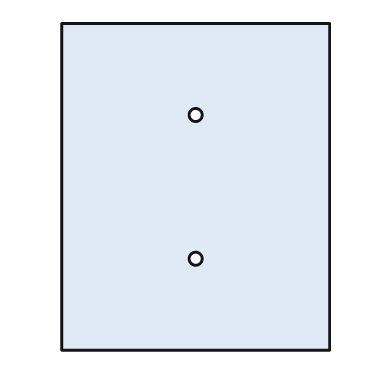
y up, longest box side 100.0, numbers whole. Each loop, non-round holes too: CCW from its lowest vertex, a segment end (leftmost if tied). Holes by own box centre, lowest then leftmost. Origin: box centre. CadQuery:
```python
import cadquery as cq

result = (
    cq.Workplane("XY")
    .moveTo(-41.0, -50.0)
    .lineTo(41.0, -50.0)
    .lineTo(41.0, 50.0)
    .lineTo(-41.0, 50.0)
    .close()
    .moveTo(0.0, -22.0)
    .circle(2.0)
    .moveTo(0.0, 22.0)
    .circle(2.0)
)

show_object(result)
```